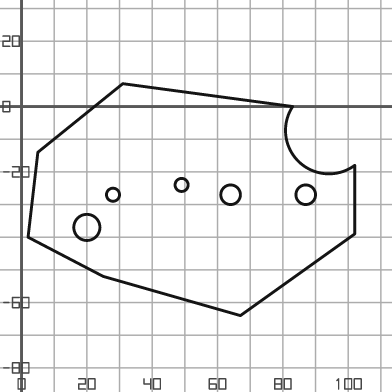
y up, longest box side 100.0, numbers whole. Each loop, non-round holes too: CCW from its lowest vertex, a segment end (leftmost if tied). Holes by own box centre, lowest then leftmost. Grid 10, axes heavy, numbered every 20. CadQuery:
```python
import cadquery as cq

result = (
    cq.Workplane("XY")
    .moveTo(67.0, -64.0)
    .lineTo(102.0, -39.0)
    .lineTo(102.0, -18.0)
    .threePointArc((85.0, -17.0), (83.0, 0.0))
    .lineTo(31.0, 7.0)
    .lineTo(5.0, -14.0)
    .lineTo(2.0, -40.0)
    .lineTo(25.0, -52.0)
    .close()
    .moveTo(20.0, -37.0)
    .circle(4.0)
    .moveTo(28.0, -27.0)
    .circle(2.0)
    .moveTo(64.0, -27.0)
    .circle(3.0)
    .moveTo(87.0, -27.0)
    .circle(3.0)
    .moveTo(49.0, -24.0)
    .circle(2.0)
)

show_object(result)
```